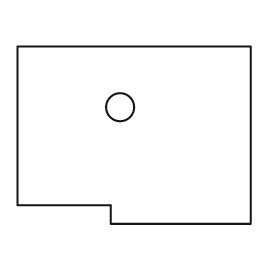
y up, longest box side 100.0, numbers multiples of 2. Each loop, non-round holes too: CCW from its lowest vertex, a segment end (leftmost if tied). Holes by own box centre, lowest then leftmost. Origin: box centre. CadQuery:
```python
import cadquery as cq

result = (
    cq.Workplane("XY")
    .moveTo(-10.0, -38.0)
    .lineTo(50.0, -38.0)
    .lineTo(50.0, 38.0)
    .lineTo(-50.0, 38.0)
    .lineTo(-50.0, -30.0)
    .lineTo(-10.0, -30.0)
    .close()
    .moveTo(-6.0, 12.0)
    .circle(6.0)
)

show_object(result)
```